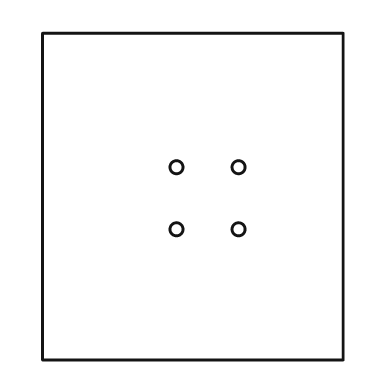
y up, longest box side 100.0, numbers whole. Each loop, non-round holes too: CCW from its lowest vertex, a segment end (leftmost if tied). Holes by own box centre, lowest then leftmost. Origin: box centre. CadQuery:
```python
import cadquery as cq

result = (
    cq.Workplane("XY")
    .moveTo(-46.0, -50.0)
    .lineTo(46.0, -50.0)
    .lineTo(46.0, 50.0)
    .lineTo(-46.0, 50.0)
    .close()
    .moveTo(-5.0, -10.0)
    .circle(2.0)
    .moveTo(14.0, -10.0)
    .circle(2.0)
    .moveTo(-5.0, 9.0)
    .circle(2.0)
    .moveTo(14.0, 9.0)
    .circle(2.0)
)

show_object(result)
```